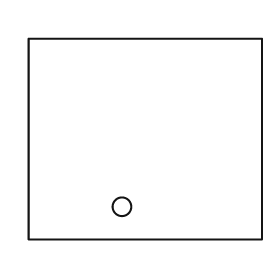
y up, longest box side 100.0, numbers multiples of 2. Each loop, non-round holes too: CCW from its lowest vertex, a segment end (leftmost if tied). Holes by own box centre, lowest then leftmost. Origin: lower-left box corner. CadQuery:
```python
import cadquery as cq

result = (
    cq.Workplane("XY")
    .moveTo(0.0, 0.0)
    .lineTo(100.0, 0.0)
    .lineTo(100.0, 86.0)
    .lineTo(0.0, 86.0)
    .close()
    .moveTo(40.0, 14.0)
    .circle(4.0)
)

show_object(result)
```